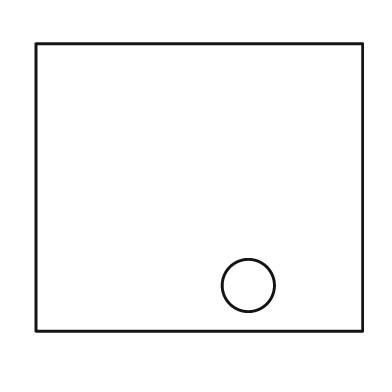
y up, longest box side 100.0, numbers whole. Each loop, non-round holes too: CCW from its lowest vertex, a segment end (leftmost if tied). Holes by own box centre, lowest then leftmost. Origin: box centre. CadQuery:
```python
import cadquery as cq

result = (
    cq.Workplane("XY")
    .moveTo(-50.0, -44.0)
    .lineTo(50.0, -44.0)
    .lineTo(50.0, 44.0)
    .lineTo(-50.0, 44.0)
    .close()
    .moveTo(15.0, -30.0)
    .circle(8.0)
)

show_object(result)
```